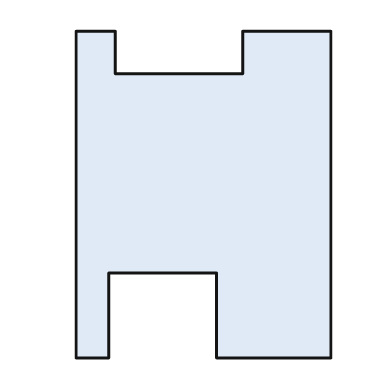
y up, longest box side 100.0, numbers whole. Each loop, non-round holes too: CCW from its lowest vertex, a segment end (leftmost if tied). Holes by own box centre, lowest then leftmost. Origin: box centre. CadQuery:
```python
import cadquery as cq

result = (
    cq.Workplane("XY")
    .moveTo(-39.0, -50.0)
    .lineTo(-29.0, -50.0)
    .lineTo(-29.0, -24.0)
    .lineTo(4.0, -24.0)
    .lineTo(4.0, -50.0)
    .lineTo(39.0, -50.0)
    .lineTo(39.0, 50.0)
    .lineTo(12.0, 50.0)
    .lineTo(12.0, 37.0)
    .lineTo(-27.0, 37.0)
    .lineTo(-27.0, 50.0)
    .lineTo(-39.0, 50.0)
    .close()
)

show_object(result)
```